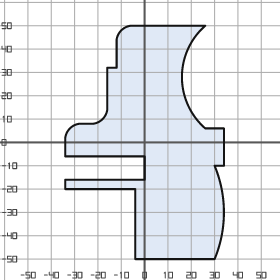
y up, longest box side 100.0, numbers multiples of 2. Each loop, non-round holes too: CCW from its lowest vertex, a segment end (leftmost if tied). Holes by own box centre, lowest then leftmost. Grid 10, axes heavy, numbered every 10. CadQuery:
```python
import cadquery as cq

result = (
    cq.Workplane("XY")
    .moveTo(-4.0, -50.0)
    .lineTo(30.0, -50.0)
    .threePointArc((34.0, -30.0), (30.0, -10.0))
    .lineTo(34.0, -10.0)
    .lineTo(34.0, 6.0)
    .lineTo(26.0, 6.0)
    .threePointArc((16.0, 28.0), (26.0, 50.0))
    .lineTo(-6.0, 50.0)
    .threePointArc((-10.0, 48.0), (-12.0, 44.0))
    .lineTo(-12.0, 32.0)
    .lineTo(-16.0, 32.0)
    .lineTo(-16.0, 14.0)
    .threePointArc((-18.0, 10.0), (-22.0, 8.0))
    .lineTo(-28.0, 8.0)
    .threePointArc((-32.0, 6.0), (-34.0, 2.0))
    .lineTo(-34.0, -6.0)
    .lineTo(0.0, -6.0)
    .lineTo(0.0, -16.0)
    .lineTo(-34.0, -16.0)
    .lineTo(-34.0, -20.0)
    .lineTo(-4.0, -20.0)
    .close()
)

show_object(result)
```